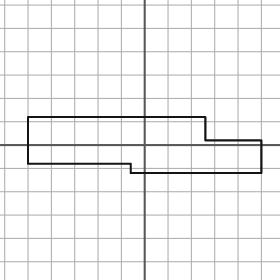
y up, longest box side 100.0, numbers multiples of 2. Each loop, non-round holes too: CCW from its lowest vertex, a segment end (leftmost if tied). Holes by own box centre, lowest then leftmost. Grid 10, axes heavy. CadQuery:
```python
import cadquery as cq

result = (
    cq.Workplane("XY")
    .moveTo(-6.0, -12.0)
    .lineTo(50.0, -12.0)
    .lineTo(50.0, 2.0)
    .lineTo(26.0, 2.0)
    .lineTo(26.0, 12.0)
    .lineTo(-50.0, 12.0)
    .lineTo(-50.0, -8.0)
    .lineTo(-6.0, -8.0)
    .close()
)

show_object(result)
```